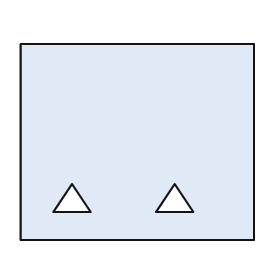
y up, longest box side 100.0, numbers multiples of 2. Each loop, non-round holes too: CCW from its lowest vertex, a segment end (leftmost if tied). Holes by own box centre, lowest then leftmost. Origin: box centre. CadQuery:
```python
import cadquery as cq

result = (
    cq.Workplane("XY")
    .moveTo(-50.0, -42.0)
    .lineTo(50.0, -42.0)
    .lineTo(50.0, 42.0)
    .lineTo(-50.0, 42.0)
    .close()
    .moveTo(-36.0, -30.0)
    .lineTo(-20.0, -30.0)
    .lineTo(-28.0, -18.0)
    .close()
    .moveTo(8.0, -30.0)
    .lineTo(24.0, -30.0)
    .lineTo(16.0, -18.0)
    .close()
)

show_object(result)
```